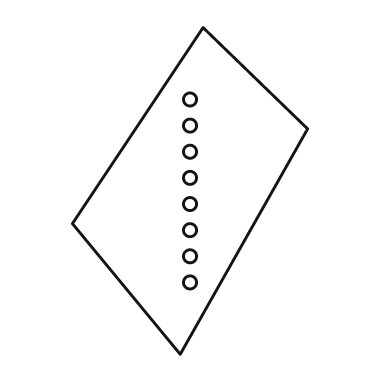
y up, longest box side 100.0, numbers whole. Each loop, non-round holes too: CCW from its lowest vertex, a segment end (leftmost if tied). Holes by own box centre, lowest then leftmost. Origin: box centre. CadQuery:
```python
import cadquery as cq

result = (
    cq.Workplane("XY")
    .moveTo(-3.0, -50.0)
    .lineTo(36.0, 19.0)
    .lineTo(4.0, 50.0)
    .lineTo(-36.0, -10.0)
    .close()
    .moveTo(0.0, -28.0)
    .circle(2.0)
    .moveTo(0.0, -20.0)
    .circle(2.0)
    .moveTo(0.0, -12.0)
    .circle(2.0)
    .moveTo(0.0, -4.0)
    .circle(2.0)
    .moveTo(0.0, 4.0)
    .circle(2.0)
    .moveTo(0.0, 12.0)
    .circle(2.0)
    .moveTo(0.0, 20.0)
    .circle(2.0)
    .moveTo(0.0, 28.0)
    .circle(2.0)
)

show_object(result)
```